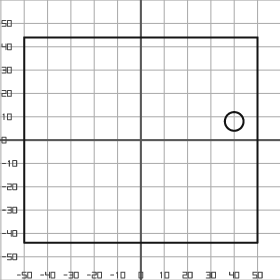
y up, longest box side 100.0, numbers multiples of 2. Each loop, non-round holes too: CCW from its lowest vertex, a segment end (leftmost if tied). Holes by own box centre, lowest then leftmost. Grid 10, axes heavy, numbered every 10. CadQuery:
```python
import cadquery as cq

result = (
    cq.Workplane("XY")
    .moveTo(-50.0, -44.0)
    .lineTo(50.0, -44.0)
    .lineTo(50.0, 44.0)
    .lineTo(-50.0, 44.0)
    .close()
    .moveTo(40.0, 8.0)
    .circle(4.0)
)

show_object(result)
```